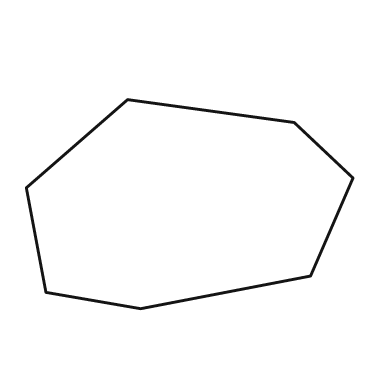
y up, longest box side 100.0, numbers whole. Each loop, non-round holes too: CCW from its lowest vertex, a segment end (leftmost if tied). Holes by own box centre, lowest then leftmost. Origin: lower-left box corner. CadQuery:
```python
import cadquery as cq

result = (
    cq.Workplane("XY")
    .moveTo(35.0, 0.0)
    .lineTo(87.0, 10.0)
    .lineTo(100.0, 40.0)
    .lineTo(82.0, 57.0)
    .lineTo(31.0, 64.0)
    .lineTo(0.0, 37.0)
    .lineTo(6.0, 5.0)
    .close()
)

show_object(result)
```